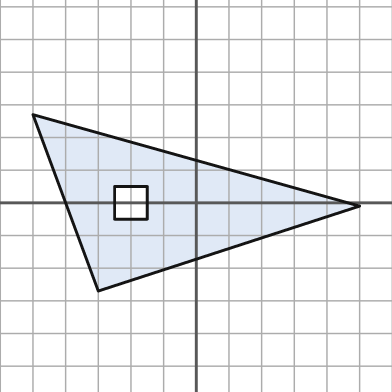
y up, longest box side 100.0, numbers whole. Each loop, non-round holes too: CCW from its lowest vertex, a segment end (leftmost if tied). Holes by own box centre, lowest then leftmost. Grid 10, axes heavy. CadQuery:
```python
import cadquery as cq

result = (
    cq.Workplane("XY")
    .moveTo(-30.0, -27.0)
    .lineTo(50.0, -1.0)
    .lineTo(-50.0, 27.0)
    .close()
    .moveTo(-25.0, -5.0)
    .lineTo(-15.0, -5.0)
    .lineTo(-15.0, 5.0)
    .lineTo(-25.0, 5.0)
    .close()
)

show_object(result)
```